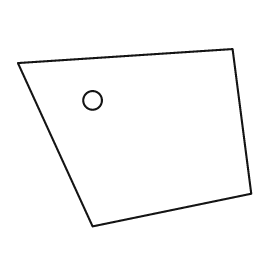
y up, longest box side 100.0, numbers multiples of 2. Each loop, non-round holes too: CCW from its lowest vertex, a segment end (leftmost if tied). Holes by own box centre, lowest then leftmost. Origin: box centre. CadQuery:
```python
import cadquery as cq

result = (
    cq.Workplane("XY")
    .moveTo(-18.0, -38.0)
    .lineTo(50.0, -24.0)
    .lineTo(42.0, 38.0)
    .lineTo(-50.0, 32.0)
    .close()
    .moveTo(-18.0, 16.0)
    .circle(4.0)
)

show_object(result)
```